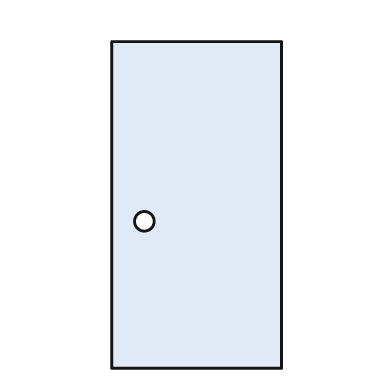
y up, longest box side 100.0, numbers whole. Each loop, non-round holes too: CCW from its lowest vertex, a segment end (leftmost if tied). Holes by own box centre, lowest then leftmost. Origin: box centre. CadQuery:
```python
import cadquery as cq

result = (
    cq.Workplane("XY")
    .moveTo(-26.0, -50.0)
    .lineTo(26.0, -50.0)
    .lineTo(26.0, 50.0)
    .lineTo(-26.0, 50.0)
    .close()
    .moveTo(-16.0, -5.0)
    .circle(3.0)
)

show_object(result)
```